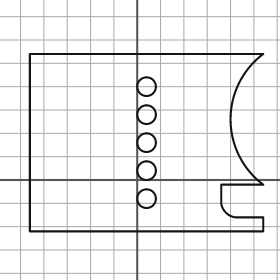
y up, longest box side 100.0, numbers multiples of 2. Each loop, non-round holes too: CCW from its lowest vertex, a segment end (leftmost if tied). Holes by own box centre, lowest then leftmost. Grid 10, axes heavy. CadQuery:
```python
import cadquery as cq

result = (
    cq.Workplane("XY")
    .moveTo(-46.0, -22.0)
    .lineTo(54.0, -22.0)
    .lineTo(54.0, -16.0)
    .lineTo(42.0, -16.0)
    .threePointArc((38.0, -14.0), (36.0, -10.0))
    .lineTo(36.0, -2.0)
    .lineTo(54.0, -2.0)
    .threePointArc((40.0, 26.0), (54.0, 54.0))
    .lineTo(-46.0, 54.0)
    .close()
    .moveTo(4.0, -8.0)
    .circle(4.0)
    .moveTo(4.0, 4.0)
    .circle(4.0)
    .moveTo(4.0, 16.0)
    .circle(4.0)
    .moveTo(4.0, 28.0)
    .circle(4.0)
    .moveTo(4.0, 40.0)
    .circle(4.0)
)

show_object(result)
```